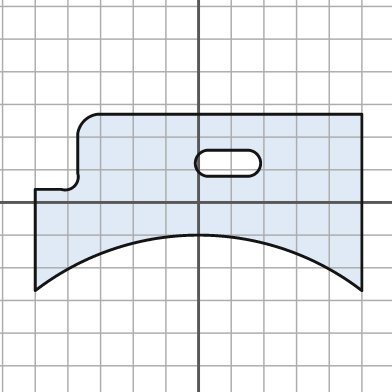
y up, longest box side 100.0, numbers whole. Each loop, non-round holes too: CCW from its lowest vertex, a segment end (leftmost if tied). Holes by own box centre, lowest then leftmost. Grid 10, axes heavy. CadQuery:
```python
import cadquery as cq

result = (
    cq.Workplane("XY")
    .moveTo(-50.0, -27.0)
    .threePointArc((0.0, -10.0), (50.0, -27.0))
    .lineTo(50.0, 27.0)
    .lineTo(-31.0, 27.0)
    .threePointArc((-35.0, 25.0), (-37.0, 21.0))
    .lineTo(-37.0, 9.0)
    .threePointArc((-38.0, 5.0), (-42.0, 4.0))
    .lineTo(-50.0, 4.0)
    .close()
    .moveTo(3.0, 8.0)
    .lineTo(15.0, 8.0)
    .threePointArc((19.0, 12.0), (15.0, 16.0))
    .lineTo(3.0, 16.0)
    .threePointArc((-1.0, 12.0), (3.0, 8.0))
    .close()
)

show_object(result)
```